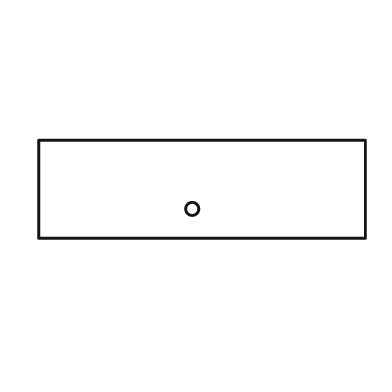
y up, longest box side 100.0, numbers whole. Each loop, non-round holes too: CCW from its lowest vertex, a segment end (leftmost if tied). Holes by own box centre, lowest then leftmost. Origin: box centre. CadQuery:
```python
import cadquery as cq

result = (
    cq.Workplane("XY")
    .moveTo(-50.0, -15.0)
    .lineTo(50.0, -15.0)
    .lineTo(50.0, 15.0)
    .lineTo(-50.0, 15.0)
    .close()
    .moveTo(-3.0, -6.0)
    .circle(2.0)
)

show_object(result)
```